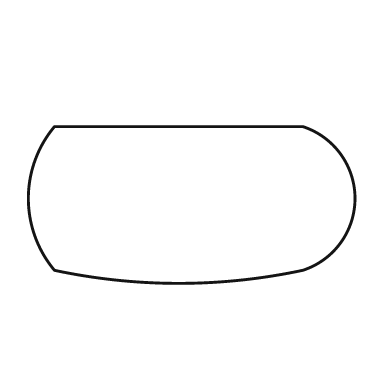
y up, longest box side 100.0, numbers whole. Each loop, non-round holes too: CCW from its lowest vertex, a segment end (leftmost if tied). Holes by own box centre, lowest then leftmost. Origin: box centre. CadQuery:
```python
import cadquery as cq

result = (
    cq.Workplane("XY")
    .moveTo(-42.0, -20.0)
    .threePointArc((-4.0, -24.0), (34.0, -20.0))
    .threePointArc((50.0, 2.0), (34.0, 24.0))
    .lineTo(-42.0, 24.0)
    .threePointArc((-50.0, 2.0), (-42.0, -20.0))
    .close()
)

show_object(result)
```